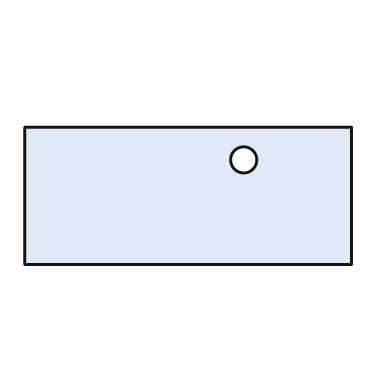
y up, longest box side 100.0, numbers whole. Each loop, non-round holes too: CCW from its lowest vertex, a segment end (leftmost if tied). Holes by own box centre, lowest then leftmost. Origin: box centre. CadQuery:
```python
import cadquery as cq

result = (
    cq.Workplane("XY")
    .moveTo(-50.0, -21.0)
    .lineTo(50.0, -21.0)
    .lineTo(50.0, 21.0)
    .lineTo(-50.0, 21.0)
    .close()
    .moveTo(17.0, 11.0)
    .circle(4.0)
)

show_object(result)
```